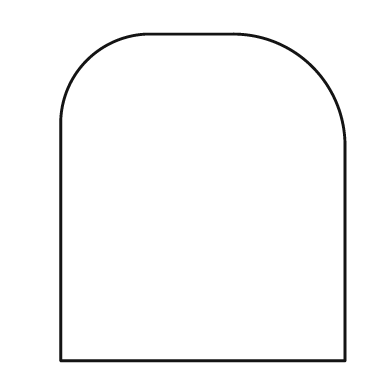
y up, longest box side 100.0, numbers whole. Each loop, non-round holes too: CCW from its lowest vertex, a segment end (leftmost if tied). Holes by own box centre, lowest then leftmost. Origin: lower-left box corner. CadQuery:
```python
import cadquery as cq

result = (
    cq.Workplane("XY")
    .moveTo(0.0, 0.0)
    .lineTo(87.0, 0.0)
    .lineTo(87.0, 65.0)
    .threePointArc((77.0, 90.0), (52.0, 100.0))
    .lineTo(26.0, 100.0)
    .threePointArc((8.0, 92.0), (0.0, 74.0))
    .close()
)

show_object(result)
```